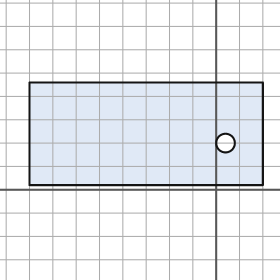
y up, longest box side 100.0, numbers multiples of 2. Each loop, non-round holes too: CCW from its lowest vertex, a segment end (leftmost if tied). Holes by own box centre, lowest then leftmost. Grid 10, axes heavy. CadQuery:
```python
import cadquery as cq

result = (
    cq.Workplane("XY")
    .moveTo(-80.0, 2.0)
    .lineTo(20.0, 2.0)
    .lineTo(20.0, 46.0)
    .lineTo(-80.0, 46.0)
    .close()
    .moveTo(4.0, 20.0)
    .circle(4.0)
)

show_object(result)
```